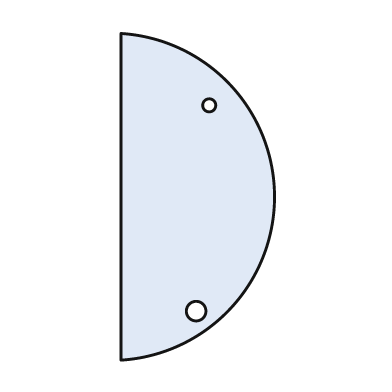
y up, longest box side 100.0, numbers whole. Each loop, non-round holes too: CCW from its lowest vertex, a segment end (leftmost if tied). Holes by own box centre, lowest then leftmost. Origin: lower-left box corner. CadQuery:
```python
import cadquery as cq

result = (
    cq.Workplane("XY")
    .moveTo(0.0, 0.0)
    .threePointArc((47.0, 50.0), (0.0, 100.0))
    .close()
    .moveTo(23.0, 15.0)
    .circle(3.0)
    .moveTo(27.0, 78.0)
    .circle(2.0)
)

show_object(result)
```